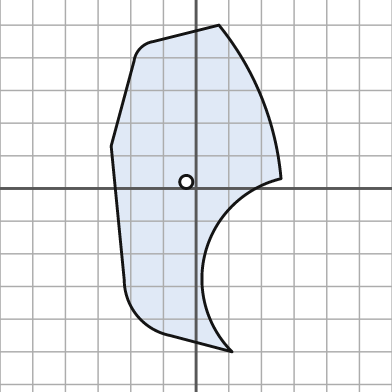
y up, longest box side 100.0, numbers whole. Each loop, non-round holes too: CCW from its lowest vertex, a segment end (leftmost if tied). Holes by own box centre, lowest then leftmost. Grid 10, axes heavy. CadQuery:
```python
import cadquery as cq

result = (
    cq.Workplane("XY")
    .moveTo(11.0, -50.0)
    .threePointArc((3.0, -19.0), (26.0, 3.0))
    .threePointArc((20.0, 28.0), (7.0, 50.0))
    .lineTo(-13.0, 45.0)
    .threePointArc((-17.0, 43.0), (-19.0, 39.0))
    .lineTo(-26.0, 13.0)
    .lineTo(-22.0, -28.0)
    .threePointArc((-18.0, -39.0), (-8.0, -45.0))
    .close()
    .moveTo(-3.0, 2.0)
    .circle(2.0)
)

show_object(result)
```